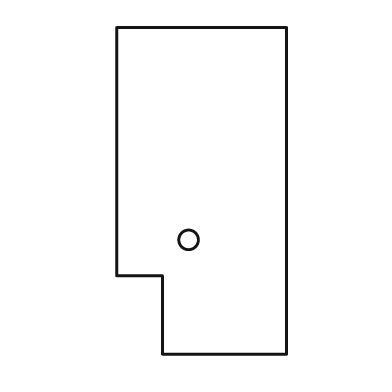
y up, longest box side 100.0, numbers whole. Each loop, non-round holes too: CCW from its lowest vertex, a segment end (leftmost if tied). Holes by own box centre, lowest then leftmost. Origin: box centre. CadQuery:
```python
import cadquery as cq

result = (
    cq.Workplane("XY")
    .moveTo(-12.0, -50.0)
    .lineTo(26.0, -50.0)
    .lineTo(26.0, 50.0)
    .lineTo(-26.0, 50.0)
    .lineTo(-26.0, -26.0)
    .lineTo(-12.0, -26.0)
    .close()
    .moveTo(-4.0, -15.0)
    .circle(3.0)
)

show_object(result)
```